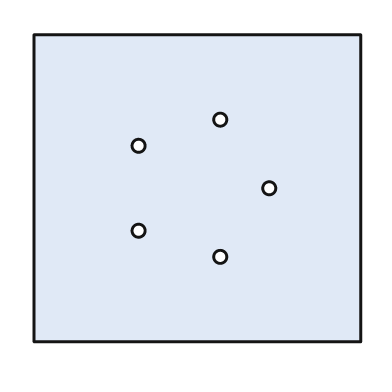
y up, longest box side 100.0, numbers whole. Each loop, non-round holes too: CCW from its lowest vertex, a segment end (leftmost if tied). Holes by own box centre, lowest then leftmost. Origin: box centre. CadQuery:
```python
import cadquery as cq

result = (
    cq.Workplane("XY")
    .moveTo(-50.0, -47.0)
    .lineTo(50.0, -47.0)
    .lineTo(50.0, 47.0)
    .lineTo(-50.0, 47.0)
    .close()
    .moveTo(7.0, -21.0)
    .circle(2.0)
    .moveTo(-18.0, -13.0)
    .circle(2.0)
    .moveTo(22.0, 0.0)
    .circle(2.0)
    .moveTo(-18.0, 13.0)
    .circle(2.0)
    .moveTo(7.0, 21.0)
    .circle(2.0)
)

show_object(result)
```